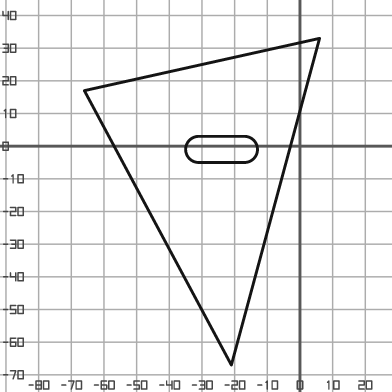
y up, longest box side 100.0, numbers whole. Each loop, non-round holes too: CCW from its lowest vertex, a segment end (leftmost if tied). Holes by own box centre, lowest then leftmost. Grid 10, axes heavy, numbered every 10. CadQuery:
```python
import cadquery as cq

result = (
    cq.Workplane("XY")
    .moveTo(-21.0, -67.0)
    .lineTo(6.0, 33.0)
    .lineTo(-66.0, 17.0)
    .close()
    .moveTo(-31.0, -5.0)
    .lineTo(-17.0, -5.0)
    .threePointArc((-13.0, -1.0), (-17.0, 3.0))
    .lineTo(-31.0, 3.0)
    .threePointArc((-35.0, -1.0), (-31.0, -5.0))
    .close()
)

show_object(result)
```